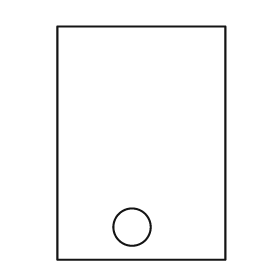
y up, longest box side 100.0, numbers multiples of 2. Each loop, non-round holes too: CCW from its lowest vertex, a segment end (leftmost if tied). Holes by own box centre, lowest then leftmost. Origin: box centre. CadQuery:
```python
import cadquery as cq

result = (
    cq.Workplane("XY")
    .moveTo(-36.0, -50.0)
    .lineTo(36.0, -50.0)
    .lineTo(36.0, 50.0)
    .lineTo(-36.0, 50.0)
    .close()
    .moveTo(-4.0, -36.0)
    .circle(8.0)
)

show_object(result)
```